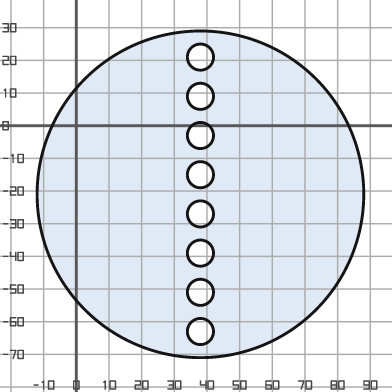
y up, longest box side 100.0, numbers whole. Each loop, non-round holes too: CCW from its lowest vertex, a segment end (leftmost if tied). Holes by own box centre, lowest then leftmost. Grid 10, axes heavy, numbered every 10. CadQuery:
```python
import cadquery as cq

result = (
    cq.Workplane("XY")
    .moveTo(38.0, -21.0)
    .circle(50.0)
    .moveTo(38.0, -63.0)
    .circle(4.0)
    .moveTo(38.0, -51.0)
    .circle(4.0)
    .moveTo(38.0, -39.0)
    .circle(4.0)
    .moveTo(38.0, -27.0)
    .circle(4.0)
    .moveTo(38.0, -15.0)
    .circle(4.0)
    .moveTo(38.0, -3.0)
    .circle(4.0)
    .moveTo(38.0, 9.0)
    .circle(4.0)
    .moveTo(38.0, 21.0)
    .circle(4.0)
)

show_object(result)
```